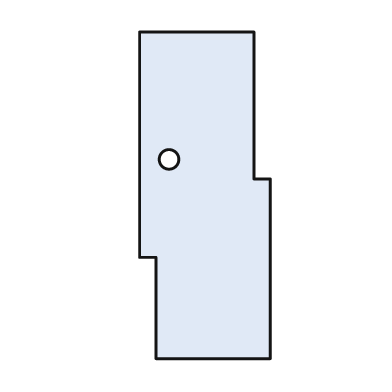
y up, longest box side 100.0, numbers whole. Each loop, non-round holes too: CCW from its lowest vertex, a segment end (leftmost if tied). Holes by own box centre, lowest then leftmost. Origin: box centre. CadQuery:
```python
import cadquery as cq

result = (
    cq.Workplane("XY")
    .moveTo(-15.0, -50.0)
    .lineTo(20.0, -50.0)
    .lineTo(20.0, 5.0)
    .lineTo(15.0, 5.0)
    .lineTo(15.0, 50.0)
    .lineTo(-20.0, 50.0)
    .lineTo(-20.0, -19.0)
    .lineTo(-15.0, -19.0)
    .close()
    .moveTo(-11.0, 11.0)
    .circle(3.0)
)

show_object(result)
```